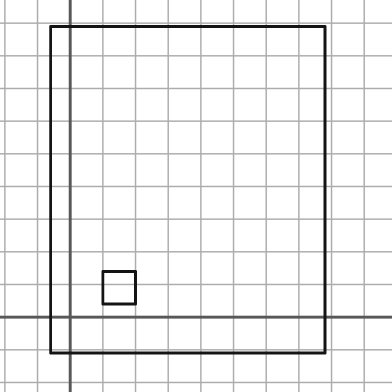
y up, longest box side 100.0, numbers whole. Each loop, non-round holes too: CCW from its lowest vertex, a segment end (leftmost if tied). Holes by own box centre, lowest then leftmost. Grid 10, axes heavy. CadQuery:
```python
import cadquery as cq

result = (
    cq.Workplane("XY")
    .moveTo(-6.0, -11.0)
    .lineTo(78.0, -11.0)
    .lineTo(78.0, 89.0)
    .lineTo(-6.0, 89.0)
    .close()
    .moveTo(10.0, 4.0)
    .lineTo(20.0, 4.0)
    .lineTo(20.0, 14.0)
    .lineTo(10.0, 14.0)
    .close()
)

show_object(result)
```